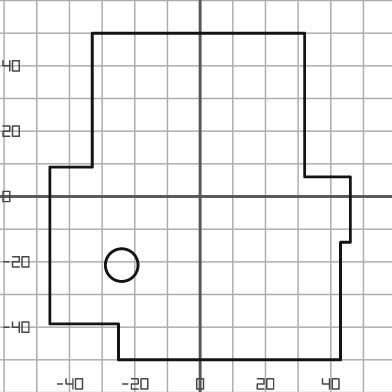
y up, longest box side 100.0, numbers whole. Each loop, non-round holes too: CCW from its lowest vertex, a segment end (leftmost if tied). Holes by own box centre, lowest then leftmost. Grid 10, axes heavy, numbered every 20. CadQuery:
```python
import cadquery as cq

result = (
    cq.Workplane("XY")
    .moveTo(-25.0, -50.0)
    .lineTo(43.0, -50.0)
    .lineTo(43.0, -14.0)
    .lineTo(46.0, -14.0)
    .lineTo(46.0, 6.0)
    .lineTo(32.0, 6.0)
    .lineTo(32.0, 50.0)
    .lineTo(-33.0, 50.0)
    .lineTo(-33.0, 9.0)
    .lineTo(-46.0, 9.0)
    .lineTo(-46.0, -39.0)
    .lineTo(-25.0, -39.0)
    .close()
    .moveTo(-24.0, -21.0)
    .circle(5.0)
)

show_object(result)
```